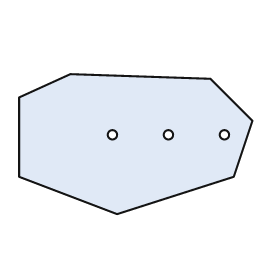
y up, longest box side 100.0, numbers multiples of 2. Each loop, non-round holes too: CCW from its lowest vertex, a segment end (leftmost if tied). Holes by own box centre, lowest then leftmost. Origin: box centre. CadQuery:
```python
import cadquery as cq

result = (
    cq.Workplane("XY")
    .moveTo(-8.0, -30.0)
    .lineTo(42.0, -14.0)
    .lineTo(50.0, 10.0)
    .lineTo(32.0, 28.0)
    .lineTo(-28.0, 30.0)
    .lineTo(-50.0, 20.0)
    .lineTo(-50.0, -14.0)
    .close()
    .moveTo(-10.0, 4.0)
    .circle(2.0)
    .moveTo(14.0, 4.0)
    .circle(2.0)
    .moveTo(38.0, 4.0)
    .circle(2.0)
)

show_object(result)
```